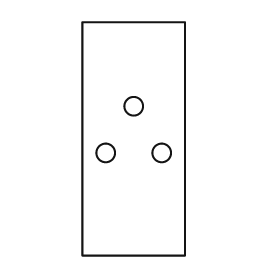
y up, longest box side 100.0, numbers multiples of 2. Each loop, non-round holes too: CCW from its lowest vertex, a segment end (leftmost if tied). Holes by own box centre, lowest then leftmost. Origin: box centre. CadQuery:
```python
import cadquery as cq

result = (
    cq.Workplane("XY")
    .moveTo(-22.0, -50.0)
    .lineTo(22.0, -50.0)
    .lineTo(22.0, 50.0)
    .lineTo(-22.0, 50.0)
    .close()
    .moveTo(-12.0, -6.0)
    .circle(4.0)
    .moveTo(12.0, -6.0)
    .circle(4.0)
    .moveTo(0.0, 14.0)
    .circle(4.0)
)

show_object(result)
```